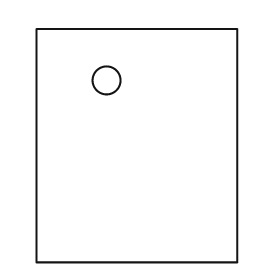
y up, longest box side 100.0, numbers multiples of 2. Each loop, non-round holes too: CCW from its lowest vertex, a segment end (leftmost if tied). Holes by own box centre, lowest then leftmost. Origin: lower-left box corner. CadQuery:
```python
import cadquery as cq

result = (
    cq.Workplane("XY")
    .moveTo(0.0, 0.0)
    .lineTo(86.0, 0.0)
    .lineTo(86.0, 100.0)
    .lineTo(0.0, 100.0)
    .close()
    .moveTo(30.0, 78.0)
    .circle(6.0)
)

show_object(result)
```